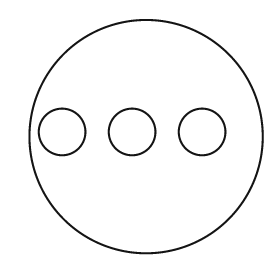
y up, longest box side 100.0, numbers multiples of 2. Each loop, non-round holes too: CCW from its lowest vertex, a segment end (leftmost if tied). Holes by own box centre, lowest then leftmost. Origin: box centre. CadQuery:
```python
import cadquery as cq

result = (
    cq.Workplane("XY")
    .moveTo(0.0, 0.0)
    .circle(50.0)
    .moveTo(-36.0, 2.0)
    .circle(10.0)
    .moveTo(-6.0, 2.0)
    .circle(10.0)
    .moveTo(24.0, 2.0)
    .circle(10.0)
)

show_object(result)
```